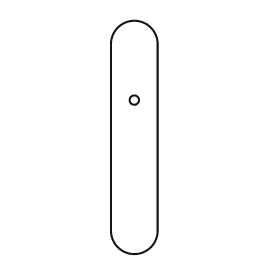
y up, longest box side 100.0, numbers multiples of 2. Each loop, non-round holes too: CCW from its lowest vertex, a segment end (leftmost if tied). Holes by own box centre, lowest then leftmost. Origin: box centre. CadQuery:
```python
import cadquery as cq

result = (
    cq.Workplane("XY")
    .moveTo(-10.0, -40.0)
    .threePointArc((0.0, -50.0), (10.0, -40.0))
    .lineTo(10.0, 40.0)
    .threePointArc((0.0, 50.0), (-10.0, 40.0))
    .close()
    .moveTo(0.0, 16.0)
    .circle(2.0)
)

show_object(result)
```